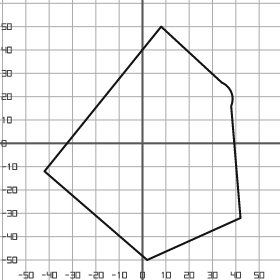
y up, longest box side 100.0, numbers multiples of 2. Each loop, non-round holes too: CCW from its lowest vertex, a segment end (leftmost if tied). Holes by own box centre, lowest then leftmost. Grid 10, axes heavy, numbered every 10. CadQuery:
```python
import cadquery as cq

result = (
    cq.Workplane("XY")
    .moveTo(2.0, -50.0)
    .lineTo(42.0, -32.0)
    .lineTo(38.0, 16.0)
    .threePointArc((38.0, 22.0), (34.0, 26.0))
    .lineTo(8.0, 50.0)
    .lineTo(-42.0, -12.0)
    .close()
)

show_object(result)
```